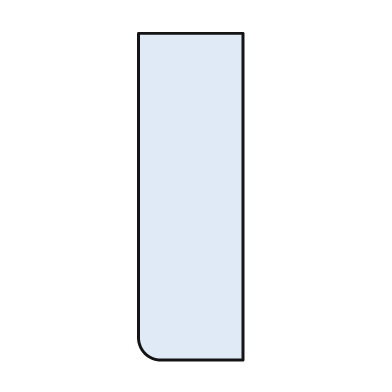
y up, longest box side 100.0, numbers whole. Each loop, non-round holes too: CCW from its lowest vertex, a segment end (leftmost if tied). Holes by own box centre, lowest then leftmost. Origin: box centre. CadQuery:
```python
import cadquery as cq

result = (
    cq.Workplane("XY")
    .moveTo(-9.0, -50.0)
    .lineTo(16.0, -50.0)
    .lineTo(16.0, 50.0)
    .lineTo(-16.0, 50.0)
    .lineTo(-16.0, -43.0)
    .threePointArc((-14.0, -48.0), (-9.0, -50.0))
    .close()
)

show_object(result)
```